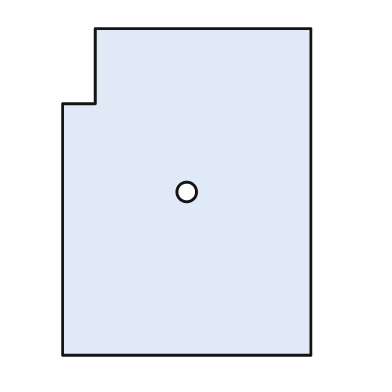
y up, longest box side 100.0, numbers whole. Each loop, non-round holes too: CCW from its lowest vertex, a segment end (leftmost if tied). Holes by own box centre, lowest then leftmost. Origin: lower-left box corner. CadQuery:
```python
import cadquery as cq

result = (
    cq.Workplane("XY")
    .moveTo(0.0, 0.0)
    .lineTo(76.0, 0.0)
    .lineTo(76.0, 100.0)
    .lineTo(10.0, 100.0)
    .lineTo(10.0, 77.0)
    .lineTo(0.0, 77.0)
    .close()
    .moveTo(38.0, 50.0)
    .circle(3.0)
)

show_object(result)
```